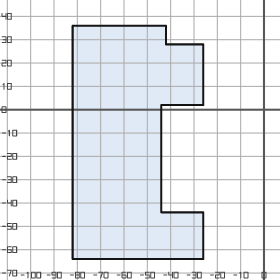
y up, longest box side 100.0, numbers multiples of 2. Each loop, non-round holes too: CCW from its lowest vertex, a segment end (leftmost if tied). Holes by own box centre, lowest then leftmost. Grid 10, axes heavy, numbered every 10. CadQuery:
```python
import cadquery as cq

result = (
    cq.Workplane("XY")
    .moveTo(-82.0, -64.0)
    .lineTo(-26.0, -64.0)
    .lineTo(-26.0, -44.0)
    .lineTo(-44.0, -44.0)
    .lineTo(-44.0, 2.0)
    .lineTo(-26.0, 2.0)
    .lineTo(-26.0, 28.0)
    .lineTo(-42.0, 28.0)
    .lineTo(-42.0, 36.0)
    .lineTo(-82.0, 36.0)
    .close()
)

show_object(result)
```